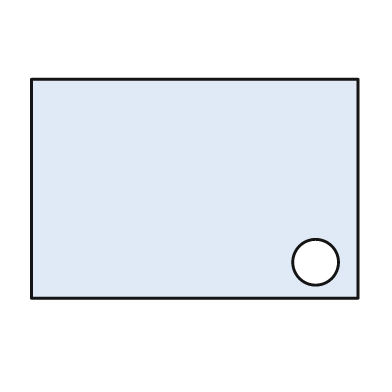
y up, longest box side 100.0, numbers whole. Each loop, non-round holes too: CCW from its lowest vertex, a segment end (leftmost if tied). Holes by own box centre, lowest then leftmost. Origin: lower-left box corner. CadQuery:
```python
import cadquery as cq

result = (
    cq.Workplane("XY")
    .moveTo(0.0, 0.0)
    .lineTo(100.0, 0.0)
    .lineTo(100.0, 67.0)
    .lineTo(0.0, 67.0)
    .close()
    .moveTo(87.0, 11.0)
    .circle(7.0)
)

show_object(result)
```